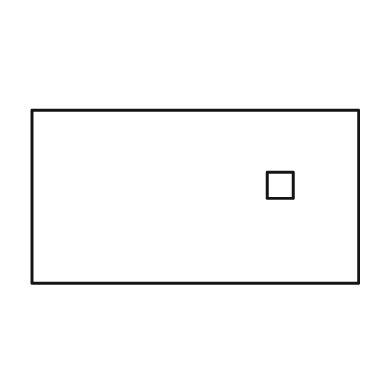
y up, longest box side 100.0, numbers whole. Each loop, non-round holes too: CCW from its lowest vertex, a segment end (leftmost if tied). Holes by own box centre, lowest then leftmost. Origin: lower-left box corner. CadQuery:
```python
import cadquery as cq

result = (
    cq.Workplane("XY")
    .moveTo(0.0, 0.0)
    .lineTo(100.0, 0.0)
    .lineTo(100.0, 53.0)
    .lineTo(0.0, 53.0)
    .close()
    .moveTo(72.0, 26.0)
    .lineTo(80.0, 26.0)
    .lineTo(80.0, 34.0)
    .lineTo(72.0, 34.0)
    .close()
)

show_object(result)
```